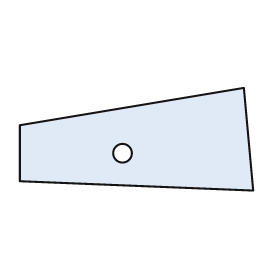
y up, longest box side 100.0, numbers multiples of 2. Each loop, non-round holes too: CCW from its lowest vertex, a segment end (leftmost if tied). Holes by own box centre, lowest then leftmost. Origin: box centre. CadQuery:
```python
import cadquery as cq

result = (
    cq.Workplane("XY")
    .moveTo(50.0, -22.0)
    .lineTo(46.0, 22.0)
    .lineTo(-50.0, 6.0)
    .lineTo(-50.0, -18.0)
    .close()
    .moveTo(-6.0, -6.0)
    .circle(4.0)
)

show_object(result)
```